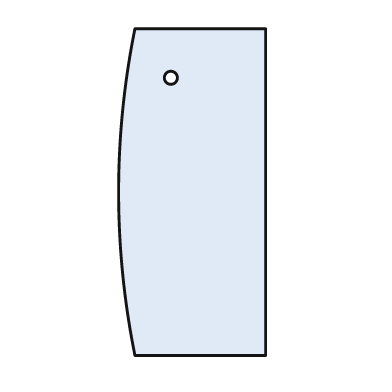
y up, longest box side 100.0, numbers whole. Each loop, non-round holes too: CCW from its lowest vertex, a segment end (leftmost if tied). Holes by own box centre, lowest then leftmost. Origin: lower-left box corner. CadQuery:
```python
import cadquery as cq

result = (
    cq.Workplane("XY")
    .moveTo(5.0, 0.0)
    .lineTo(45.0, 0.0)
    .lineTo(45.0, 100.0)
    .lineTo(5.0, 100.0)
    .threePointArc((0.0, 50.0), (5.0, 0.0))
    .close()
    .moveTo(16.0, 85.0)
    .circle(2.0)
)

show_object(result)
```